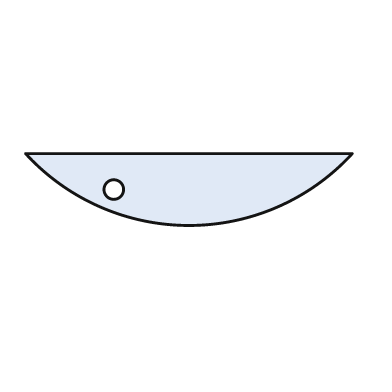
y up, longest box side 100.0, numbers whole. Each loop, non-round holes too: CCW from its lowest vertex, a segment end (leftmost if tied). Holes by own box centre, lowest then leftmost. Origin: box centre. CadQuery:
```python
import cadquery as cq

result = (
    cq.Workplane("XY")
    .moveTo(-50.0, 11.0)
    .threePointArc((0.0, -11.0), (50.0, 11.0))
    .close()
    .moveTo(-23.0, 0.0)
    .circle(3.0)
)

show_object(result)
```